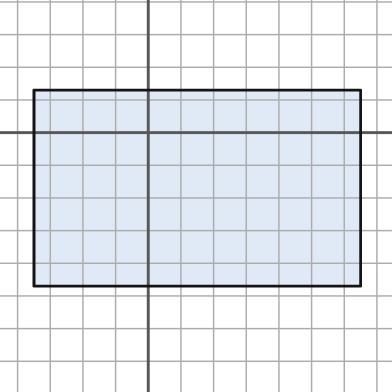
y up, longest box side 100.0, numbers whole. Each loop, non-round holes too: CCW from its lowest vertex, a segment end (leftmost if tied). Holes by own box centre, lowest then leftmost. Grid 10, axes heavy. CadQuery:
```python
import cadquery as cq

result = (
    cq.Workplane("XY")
    .moveTo(-35.0, -47.0)
    .lineTo(65.0, -47.0)
    .lineTo(65.0, 13.0)
    .lineTo(-35.0, 13.0)
    .close()
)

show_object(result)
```